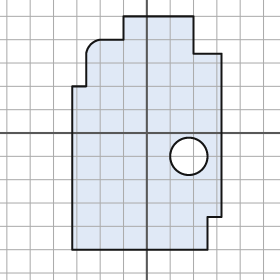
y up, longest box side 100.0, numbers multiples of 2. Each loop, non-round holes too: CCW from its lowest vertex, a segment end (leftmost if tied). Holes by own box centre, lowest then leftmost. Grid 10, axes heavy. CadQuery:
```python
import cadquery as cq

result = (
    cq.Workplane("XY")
    .moveTo(-32.0, -50.0)
    .lineTo(26.0, -50.0)
    .lineTo(26.0, -36.0)
    .lineTo(32.0, -36.0)
    .lineTo(32.0, 34.0)
    .lineTo(20.0, 34.0)
    .lineTo(20.0, 50.0)
    .lineTo(-10.0, 50.0)
    .lineTo(-10.0, 40.0)
    .lineTo(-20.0, 40.0)
    .threePointArc((-24.0, 38.0), (-26.0, 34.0))
    .lineTo(-26.0, 20.0)
    .lineTo(-32.0, 20.0)
    .close()
    .moveTo(18.0, -10.0)
    .circle(8.0)
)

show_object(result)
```